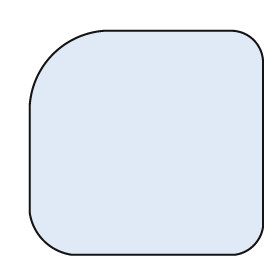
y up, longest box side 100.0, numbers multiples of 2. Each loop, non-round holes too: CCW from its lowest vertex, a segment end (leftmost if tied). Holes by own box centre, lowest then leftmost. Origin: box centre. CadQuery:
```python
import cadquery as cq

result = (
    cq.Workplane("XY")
    .moveTo(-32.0, -48.0)
    .lineTo(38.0, -48.0)
    .threePointArc((46.0, -44.0), (50.0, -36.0))
    .lineTo(50.0, 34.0)
    .threePointArc((46.0, 44.0), (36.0, 48.0))
    .lineTo(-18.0, 48.0)
    .threePointArc((-40.0, 38.0), (-50.0, 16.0))
    .lineTo(-50.0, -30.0)
    .threePointArc((-44.0, -42.0), (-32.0, -48.0))
    .close()
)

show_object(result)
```